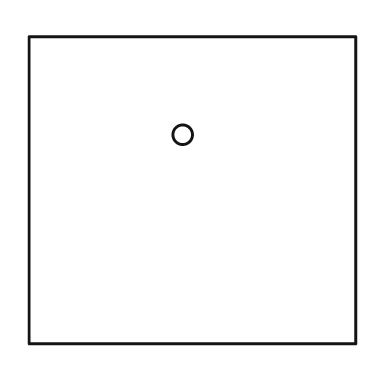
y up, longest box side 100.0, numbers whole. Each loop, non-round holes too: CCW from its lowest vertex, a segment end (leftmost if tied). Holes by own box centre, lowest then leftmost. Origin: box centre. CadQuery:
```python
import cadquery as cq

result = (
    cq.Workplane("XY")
    .moveTo(-50.0, -47.0)
    .lineTo(50.0, -47.0)
    .lineTo(50.0, 47.0)
    .lineTo(-50.0, 47.0)
    .close()
    .moveTo(-3.0, 17.0)
    .circle(3.0)
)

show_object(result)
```